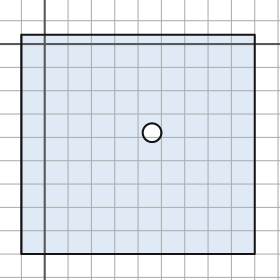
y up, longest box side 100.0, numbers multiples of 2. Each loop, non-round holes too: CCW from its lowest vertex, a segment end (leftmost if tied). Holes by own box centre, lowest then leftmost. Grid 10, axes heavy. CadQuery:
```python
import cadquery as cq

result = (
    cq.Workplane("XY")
    .moveTo(-10.0, -90.0)
    .lineTo(90.0, -90.0)
    .lineTo(90.0, 4.0)
    .lineTo(-10.0, 4.0)
    .close()
    .moveTo(46.0, -38.0)
    .circle(4.0)
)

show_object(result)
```